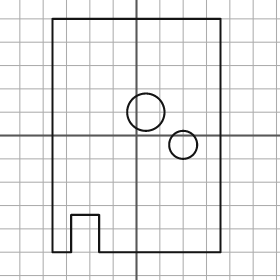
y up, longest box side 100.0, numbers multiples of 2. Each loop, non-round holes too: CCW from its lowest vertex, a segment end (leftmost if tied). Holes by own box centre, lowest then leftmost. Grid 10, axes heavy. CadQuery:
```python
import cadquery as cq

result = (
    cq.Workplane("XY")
    .moveTo(-36.0, -50.0)
    .lineTo(-28.0, -50.0)
    .lineTo(-28.0, -34.0)
    .lineTo(-16.0, -34.0)
    .lineTo(-16.0, -50.0)
    .lineTo(36.0, -50.0)
    .lineTo(36.0, 50.0)
    .lineTo(-36.0, 50.0)
    .close()
    .moveTo(20.0, -4.0)
    .circle(6.0)
    .moveTo(4.0, 10.0)
    .circle(8.0)
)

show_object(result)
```